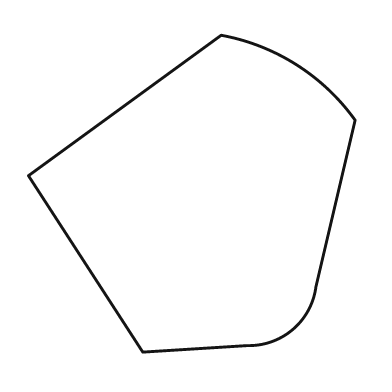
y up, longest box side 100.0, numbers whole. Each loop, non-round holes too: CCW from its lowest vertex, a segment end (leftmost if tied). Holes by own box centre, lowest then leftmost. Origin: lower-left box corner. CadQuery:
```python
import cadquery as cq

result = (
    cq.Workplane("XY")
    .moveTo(35.0, 0.0)
    .lineTo(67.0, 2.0)
    .threePointArc((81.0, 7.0), (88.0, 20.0))
    .lineTo(100.0, 71.0)
    .threePointArc((82.0, 88.0), (59.0, 97.0))
    .lineTo(0.0, 54.0)
    .close()
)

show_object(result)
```